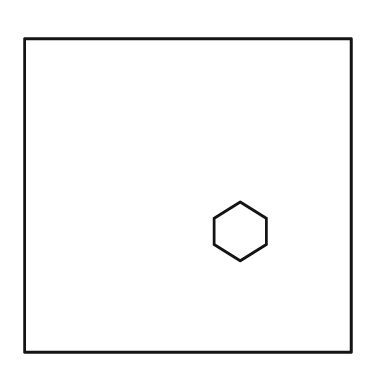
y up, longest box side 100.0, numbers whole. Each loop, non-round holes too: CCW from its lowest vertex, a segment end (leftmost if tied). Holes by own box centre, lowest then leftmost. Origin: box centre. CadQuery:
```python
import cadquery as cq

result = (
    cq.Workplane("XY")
    .moveTo(-50.0, -48.0)
    .lineTo(50.0, -48.0)
    .lineTo(50.0, 48.0)
    .lineTo(-50.0, 48.0)
    .close()
    .moveTo(16.0, -20.0)
    .lineTo(24.0, -15.0)
    .lineTo(24.0, -7.0)
    .lineTo(16.0, -2.0)
    .lineTo(8.0, -7.0)
    .lineTo(8.0, -15.0)
    .close()
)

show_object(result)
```